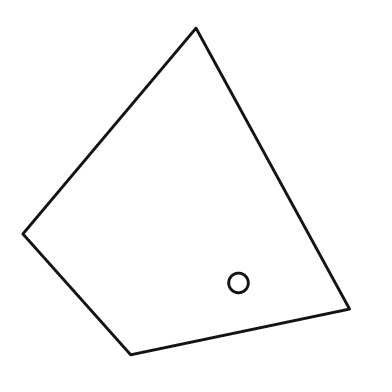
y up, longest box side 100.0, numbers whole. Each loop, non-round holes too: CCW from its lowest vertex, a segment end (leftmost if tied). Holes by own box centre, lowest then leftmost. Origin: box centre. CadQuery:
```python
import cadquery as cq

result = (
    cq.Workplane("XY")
    .moveTo(-17.0, -50.0)
    .lineTo(50.0, -36.0)
    .lineTo(3.0, 50.0)
    .lineTo(-50.0, -13.0)
    .close()
    .moveTo(16.0, -28.0)
    .circle(3.0)
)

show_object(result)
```